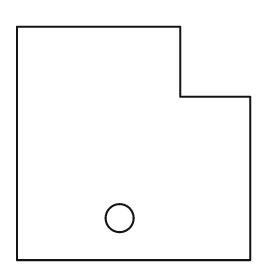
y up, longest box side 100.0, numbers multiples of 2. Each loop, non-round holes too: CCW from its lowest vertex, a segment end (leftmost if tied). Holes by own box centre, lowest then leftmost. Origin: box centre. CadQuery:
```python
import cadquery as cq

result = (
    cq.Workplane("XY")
    .moveTo(-50.0, -50.0)
    .lineTo(50.0, -50.0)
    .lineTo(50.0, 20.0)
    .lineTo(20.0, 20.0)
    .lineTo(20.0, 50.0)
    .lineTo(-50.0, 50.0)
    .close()
    .moveTo(-6.0, -32.0)
    .circle(6.0)
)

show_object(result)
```